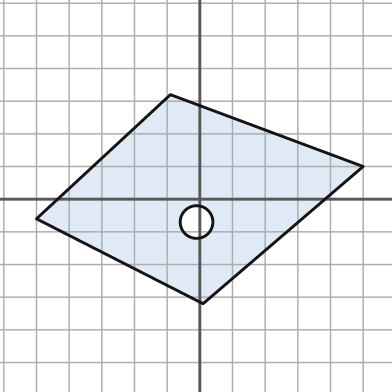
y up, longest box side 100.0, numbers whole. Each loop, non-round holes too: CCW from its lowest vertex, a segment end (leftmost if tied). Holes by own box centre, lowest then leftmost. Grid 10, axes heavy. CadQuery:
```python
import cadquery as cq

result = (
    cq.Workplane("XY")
    .moveTo(1.0, -32.0)
    .lineTo(50.0, 10.0)
    .lineTo(-9.0, 32.0)
    .lineTo(-50.0, -6.0)
    .close()
    .moveTo(-1.0, -7.0)
    .circle(5.0)
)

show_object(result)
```